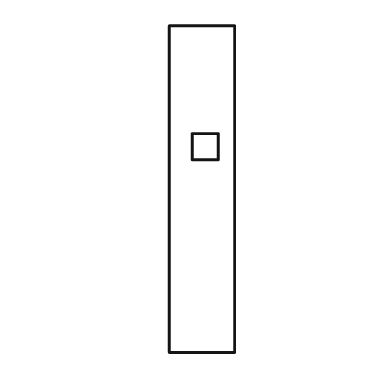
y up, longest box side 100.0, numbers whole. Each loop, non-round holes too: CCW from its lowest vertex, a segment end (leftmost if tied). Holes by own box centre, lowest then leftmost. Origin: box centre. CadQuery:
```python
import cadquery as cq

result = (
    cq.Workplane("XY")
    .moveTo(-10.0, -50.0)
    .lineTo(10.0, -50.0)
    .lineTo(10.0, 50.0)
    .lineTo(-10.0, 50.0)
    .close()
    .moveTo(-3.0, 9.0)
    .lineTo(5.0, 9.0)
    .lineTo(5.0, 17.0)
    .lineTo(-3.0, 17.0)
    .close()
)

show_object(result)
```